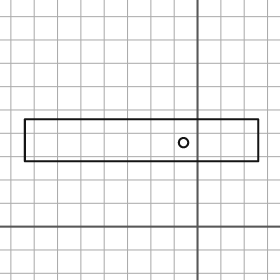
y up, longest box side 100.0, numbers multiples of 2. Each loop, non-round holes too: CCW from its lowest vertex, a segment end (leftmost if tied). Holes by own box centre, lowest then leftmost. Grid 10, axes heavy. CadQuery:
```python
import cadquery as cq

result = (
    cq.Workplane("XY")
    .moveTo(-74.0, 28.0)
    .lineTo(26.0, 28.0)
    .lineTo(26.0, 46.0)
    .lineTo(-74.0, 46.0)
    .close()
    .moveTo(-6.0, 36.0)
    .circle(2.0)
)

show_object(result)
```